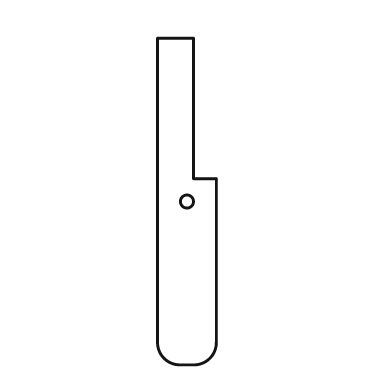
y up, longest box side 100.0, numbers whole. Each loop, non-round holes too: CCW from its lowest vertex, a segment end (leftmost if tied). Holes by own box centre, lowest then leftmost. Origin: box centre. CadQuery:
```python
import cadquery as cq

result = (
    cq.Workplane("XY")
    .moveTo(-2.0, -50.0)
    .lineTo(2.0, -50.0)
    .threePointArc((7.0, -48.0), (9.0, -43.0))
    .lineTo(9.0, 7.0)
    .lineTo(2.0, 7.0)
    .lineTo(2.0, 50.0)
    .lineTo(-9.0, 50.0)
    .lineTo(-9.0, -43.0)
    .threePointArc((-7.0, -48.0), (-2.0, -50.0))
    .close()
    .moveTo(0.0, 0.0)
    .circle(2.0)
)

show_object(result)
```